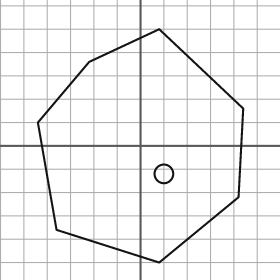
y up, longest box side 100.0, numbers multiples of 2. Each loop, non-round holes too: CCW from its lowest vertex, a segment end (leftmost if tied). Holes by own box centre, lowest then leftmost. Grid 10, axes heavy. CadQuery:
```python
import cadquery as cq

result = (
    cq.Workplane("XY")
    .moveTo(8.0, -50.0)
    .lineTo(42.0, -22.0)
    .lineTo(44.0, 16.0)
    .lineTo(8.0, 50.0)
    .lineTo(-22.0, 36.0)
    .lineTo(-44.0, 10.0)
    .lineTo(-36.0, -36.0)
    .close()
    .moveTo(10.0, -12.0)
    .circle(4.0)
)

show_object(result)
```